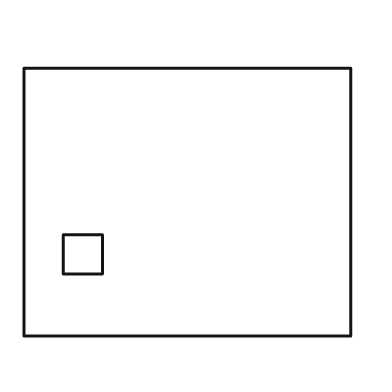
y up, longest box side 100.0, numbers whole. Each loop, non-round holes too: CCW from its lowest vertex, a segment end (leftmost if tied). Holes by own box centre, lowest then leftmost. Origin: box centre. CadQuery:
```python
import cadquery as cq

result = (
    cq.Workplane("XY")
    .moveTo(-50.0, -41.0)
    .lineTo(50.0, -41.0)
    .lineTo(50.0, 41.0)
    .lineTo(-50.0, 41.0)
    .close()
    .moveTo(-38.0, -22.0)
    .lineTo(-26.0, -22.0)
    .lineTo(-26.0, -10.0)
    .lineTo(-38.0, -10.0)
    .close()
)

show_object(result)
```